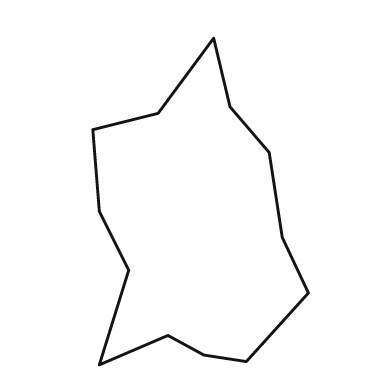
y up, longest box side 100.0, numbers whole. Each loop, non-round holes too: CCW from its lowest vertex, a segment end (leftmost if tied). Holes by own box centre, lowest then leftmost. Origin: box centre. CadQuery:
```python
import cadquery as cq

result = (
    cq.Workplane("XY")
    .moveTo(-31.0, -50.0)
    .lineTo(-10.0, -41.0)
    .lineTo(1.0, -47.0)
    .lineTo(14.0, -49.0)
    .lineTo(33.0, -28.0)
    .lineTo(25.0, -11.0)
    .lineTo(21.0, 15.0)
    .lineTo(9.0, 29.0)
    .lineTo(4.0, 50.0)
    .lineTo(-13.0, 27.0)
    .lineTo(-33.0, 22.0)
    .lineTo(-31.0, -3.0)
    .lineTo(-22.0, -21.0)
    .close()
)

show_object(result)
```